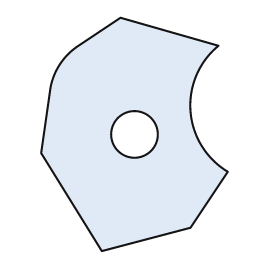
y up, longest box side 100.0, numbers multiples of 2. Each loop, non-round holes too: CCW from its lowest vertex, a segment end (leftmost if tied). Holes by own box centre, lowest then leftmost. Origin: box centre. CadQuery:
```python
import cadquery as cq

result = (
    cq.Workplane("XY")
    .moveTo(-14.0, -50.0)
    .lineTo(24.0, -40.0)
    .lineTo(40.0, -16.0)
    .threePointArc((24.0, 10.0), (36.0, 38.0))
    .lineTo(-6.0, 50.0)
    .lineTo(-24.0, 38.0)
    .threePointArc((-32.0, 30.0), (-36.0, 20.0))
    .lineTo(-40.0, -8.0)
    .close()
    .moveTo(0.0, 0.0)
    .circle(10.0)
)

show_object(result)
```